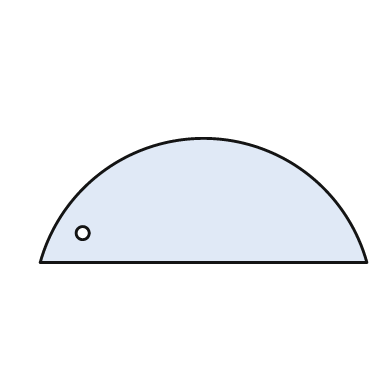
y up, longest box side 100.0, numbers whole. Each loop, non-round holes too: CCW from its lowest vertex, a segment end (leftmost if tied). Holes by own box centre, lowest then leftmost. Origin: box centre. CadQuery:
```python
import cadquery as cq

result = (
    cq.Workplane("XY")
    .moveTo(-50.0, -19.0)
    .lineTo(50.0, -19.0)
    .threePointArc((0.0, 19.0), (-50.0, -19.0))
    .close()
    .moveTo(-37.0, -10.0)
    .circle(2.0)
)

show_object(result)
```